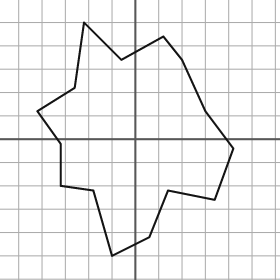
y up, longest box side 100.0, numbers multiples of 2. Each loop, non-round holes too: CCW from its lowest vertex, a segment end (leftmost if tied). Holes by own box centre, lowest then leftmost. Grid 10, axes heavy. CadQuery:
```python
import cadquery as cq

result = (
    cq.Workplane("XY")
    .moveTo(-10.0, -50.0)
    .lineTo(6.0, -42.0)
    .lineTo(14.0, -22.0)
    .lineTo(34.0, -26.0)
    .lineTo(42.0, -4.0)
    .lineTo(30.0, 12.0)
    .lineTo(20.0, 34.0)
    .lineTo(12.0, 44.0)
    .lineTo(-6.0, 34.0)
    .lineTo(-22.0, 50.0)
    .lineTo(-26.0, 22.0)
    .lineTo(-42.0, 12.0)
    .lineTo(-32.0, -2.0)
    .lineTo(-32.0, -20.0)
    .lineTo(-18.0, -22.0)
    .close()
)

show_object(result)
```